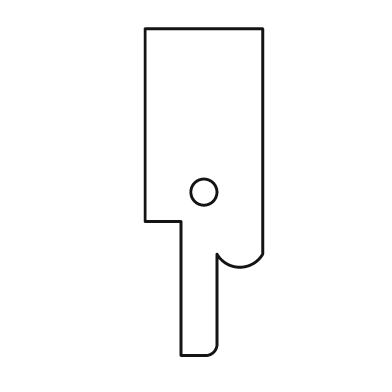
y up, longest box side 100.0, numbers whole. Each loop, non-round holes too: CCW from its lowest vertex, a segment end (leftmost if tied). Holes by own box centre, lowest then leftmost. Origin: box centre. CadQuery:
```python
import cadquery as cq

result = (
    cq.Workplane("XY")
    .moveTo(-7.0, -50.0)
    .lineTo(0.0, -50.0)
    .threePointArc((3.0, -49.0), (4.0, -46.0))
    .lineTo(4.0, -19.0)
    .threePointArc((11.0, -23.0), (18.0, -19.0))
    .lineTo(18.0, 50.0)
    .lineTo(-18.0, 50.0)
    .lineTo(-18.0, -9.0)
    .lineTo(-7.0, -9.0)
    .close()
    .moveTo(0.0, 0.0)
    .circle(4.0)
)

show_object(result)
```